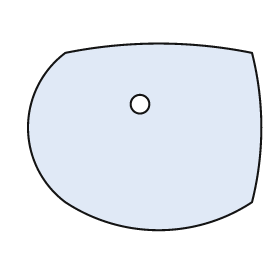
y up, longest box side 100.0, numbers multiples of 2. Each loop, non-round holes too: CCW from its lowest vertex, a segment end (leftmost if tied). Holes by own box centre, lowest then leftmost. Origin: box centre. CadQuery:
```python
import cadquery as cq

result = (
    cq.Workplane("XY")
    .moveTo(-34.0, -28.0)
    .threePointArc((6.0, -40.0), (46.0, -28.0))
    .threePointArc((50.0, 4.0), (46.0, 36.0))
    .threePointArc((6.0, 40.0), (-34.0, 36.0))
    .threePointArc((-50.0, 4.0), (-34.0, -28.0))
    .close()
    .moveTo(-2.0, 14.0)
    .circle(4.0)
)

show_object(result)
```